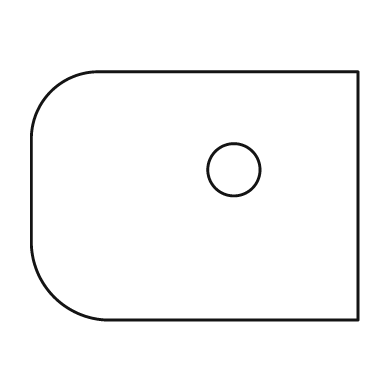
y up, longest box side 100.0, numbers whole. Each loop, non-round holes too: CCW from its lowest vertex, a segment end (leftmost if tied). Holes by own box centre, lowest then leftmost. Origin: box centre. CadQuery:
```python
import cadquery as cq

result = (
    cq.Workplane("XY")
    .moveTo(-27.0, -38.0)
    .lineTo(50.0, -38.0)
    .lineTo(50.0, 38.0)
    .lineTo(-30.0, 38.0)
    .threePointArc((-44.0, 32.0), (-50.0, 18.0))
    .lineTo(-50.0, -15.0)
    .threePointArc((-43.0, -31.0), (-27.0, -38.0))
    .close()
    .moveTo(12.0, 8.0)
    .circle(8.0)
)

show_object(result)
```